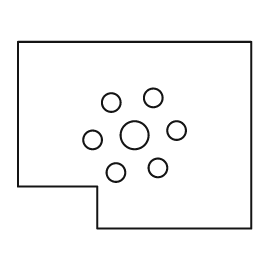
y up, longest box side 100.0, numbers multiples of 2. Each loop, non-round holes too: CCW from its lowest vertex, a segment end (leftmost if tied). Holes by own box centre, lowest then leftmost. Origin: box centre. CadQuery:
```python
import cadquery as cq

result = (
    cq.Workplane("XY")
    .moveTo(-16.0, -40.0)
    .lineTo(50.0, -40.0)
    .lineTo(50.0, 40.0)
    .lineTo(-50.0, 40.0)
    .lineTo(-50.0, -22.0)
    .lineTo(-16.0, -22.0)
    .close()
    .moveTo(-8.0, -16.0)
    .circle(4.0)
    .moveTo(10.0, -14.0)
    .circle(4.0)
    .moveTo(-18.0, -2.0)
    .circle(4.0)
    .moveTo(0.0, 0.0)
    .circle(6.0)
    .moveTo(18.0, 2.0)
    .circle(4.0)
    .moveTo(-10.0, 14.0)
    .circle(4.0)
    .moveTo(8.0, 16.0)
    .circle(4.0)
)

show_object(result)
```